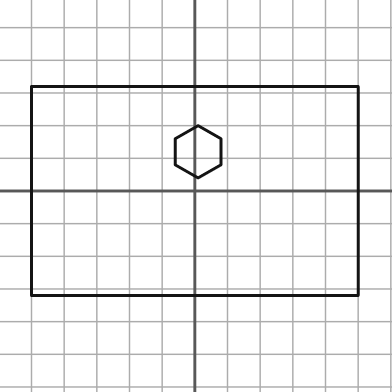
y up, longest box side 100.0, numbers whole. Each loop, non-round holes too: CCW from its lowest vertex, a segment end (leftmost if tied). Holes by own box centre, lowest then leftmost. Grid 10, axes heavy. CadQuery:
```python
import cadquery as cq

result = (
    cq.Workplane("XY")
    .moveTo(-50.0, -32.0)
    .lineTo(50.0, -32.0)
    .lineTo(50.0, 32.0)
    .lineTo(-50.0, 32.0)
    .close()
    .moveTo(1.0, 4.0)
    .lineTo(8.0, 8.0)
    .lineTo(8.0, 16.0)
    .lineTo(1.0, 20.0)
    .lineTo(-6.0, 16.0)
    .lineTo(-6.0, 8.0)
    .close()
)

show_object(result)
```